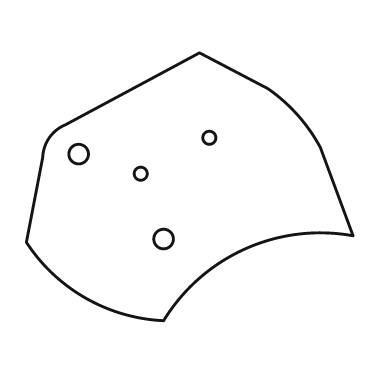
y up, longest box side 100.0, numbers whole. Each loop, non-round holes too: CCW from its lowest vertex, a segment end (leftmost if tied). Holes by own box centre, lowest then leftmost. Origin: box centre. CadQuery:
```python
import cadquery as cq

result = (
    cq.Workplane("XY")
    .moveTo(-8.0, -41.0)
    .threePointArc((17.0, -19.0), (50.0, -15.0))
    .lineTo(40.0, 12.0)
    .threePointArc((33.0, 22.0), (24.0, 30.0))
    .lineTo(3.0, 41.0)
    .lineTo(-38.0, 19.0)
    .threePointArc((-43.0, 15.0), (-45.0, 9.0))
    .lineTo(-50.0, -17.0)
    .threePointArc((-32.0, -34.0), (-8.0, -41.0))
    .close()
    .moveTo(-8.0, -16.0)
    .circle(3.0)
    .moveTo(-15.0, 4.0)
    .circle(2.0)
    .moveTo(-34.0, 10.0)
    .circle(3.0)
    .moveTo(6.0, 15.0)
    .circle(2.0)
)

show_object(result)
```